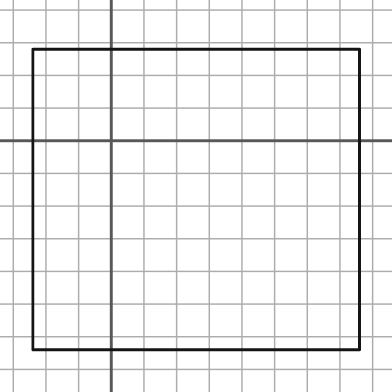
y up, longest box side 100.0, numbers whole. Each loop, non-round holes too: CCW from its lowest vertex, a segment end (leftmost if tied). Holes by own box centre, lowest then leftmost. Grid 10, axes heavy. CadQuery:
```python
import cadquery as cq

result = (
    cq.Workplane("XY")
    .moveTo(-24.0, -64.0)
    .lineTo(76.0, -64.0)
    .lineTo(76.0, 28.0)
    .lineTo(-24.0, 28.0)
    .close()
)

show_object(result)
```